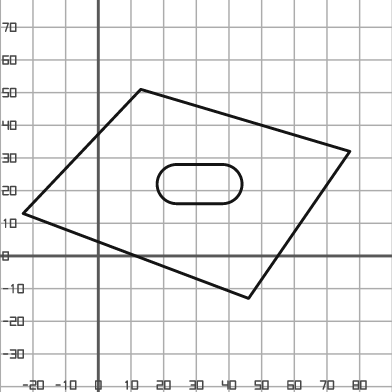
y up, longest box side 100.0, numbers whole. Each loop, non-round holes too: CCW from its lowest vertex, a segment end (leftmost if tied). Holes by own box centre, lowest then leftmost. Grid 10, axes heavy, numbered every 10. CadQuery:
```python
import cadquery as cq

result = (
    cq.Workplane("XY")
    .moveTo(46.0, -13.0)
    .lineTo(77.0, 32.0)
    .lineTo(13.0, 51.0)
    .lineTo(-23.0, 13.0)
    .close()
    .moveTo(24.0, 16.0)
    .lineTo(38.0, 16.0)
    .threePointArc((44.0, 22.0), (38.0, 28.0))
    .lineTo(24.0, 28.0)
    .threePointArc((18.0, 22.0), (24.0, 16.0))
    .close()
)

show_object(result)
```